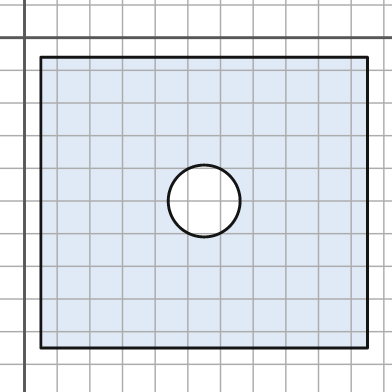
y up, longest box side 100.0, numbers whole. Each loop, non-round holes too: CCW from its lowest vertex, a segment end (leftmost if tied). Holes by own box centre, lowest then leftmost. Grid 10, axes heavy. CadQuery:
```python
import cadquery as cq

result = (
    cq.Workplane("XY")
    .moveTo(5.0, -95.0)
    .lineTo(105.0, -95.0)
    .lineTo(105.0, -6.0)
    .lineTo(5.0, -6.0)
    .close()
    .moveTo(55.0, -50.0)
    .circle(11.0)
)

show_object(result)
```